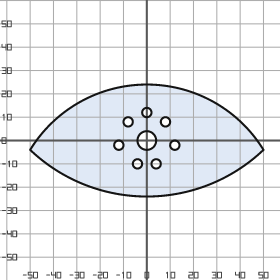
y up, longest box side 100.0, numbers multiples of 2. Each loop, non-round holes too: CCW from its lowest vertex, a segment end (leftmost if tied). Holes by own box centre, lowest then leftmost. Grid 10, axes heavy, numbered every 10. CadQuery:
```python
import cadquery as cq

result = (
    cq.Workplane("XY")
    .moveTo(-50.0, -4.0)
    .threePointArc((0.0, -24.0), (50.0, -4.0))
    .threePointArc((0.0, 24.0), (-50.0, -4.0))
    .close()
    .moveTo(-4.0, -10.0)
    .circle(2.0)
    .moveTo(4.0, -10.0)
    .circle(2.0)
    .moveTo(-12.0, -2.0)
    .circle(2.0)
    .moveTo(12.0, -2.0)
    .circle(2.0)
    .moveTo(0.0, 0.0)
    .circle(4.0)
    .moveTo(-8.0, 8.0)
    .circle(2.0)
    .moveTo(8.0, 8.0)
    .circle(2.0)
    .moveTo(0.0, 12.0)
    .circle(2.0)
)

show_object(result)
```